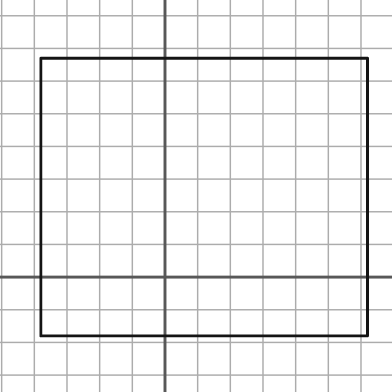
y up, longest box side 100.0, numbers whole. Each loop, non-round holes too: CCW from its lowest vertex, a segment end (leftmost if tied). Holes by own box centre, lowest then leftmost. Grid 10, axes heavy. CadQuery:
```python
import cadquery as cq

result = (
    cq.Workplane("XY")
    .moveTo(-38.0, -18.0)
    .lineTo(62.0, -18.0)
    .lineTo(62.0, 67.0)
    .lineTo(-38.0, 67.0)
    .close()
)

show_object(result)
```